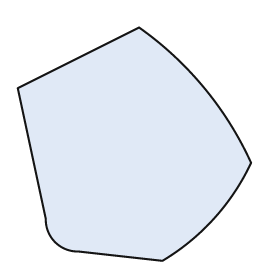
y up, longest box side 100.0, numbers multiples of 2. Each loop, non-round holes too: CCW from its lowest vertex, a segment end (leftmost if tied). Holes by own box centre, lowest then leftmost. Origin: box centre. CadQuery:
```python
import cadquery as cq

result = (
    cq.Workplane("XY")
    .moveTo(12.0, -50.0)
    .threePointArc((34.0, -32.0), (50.0, -8.0))
    .threePointArc((30.0, 24.0), (2.0, 50.0))
    .lineTo(-50.0, 24.0)
    .lineTo(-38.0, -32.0)
    .threePointArc((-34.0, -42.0), (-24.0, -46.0))
    .close()
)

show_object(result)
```